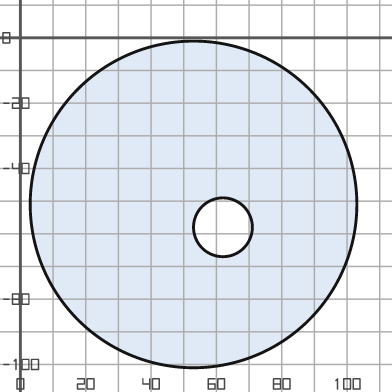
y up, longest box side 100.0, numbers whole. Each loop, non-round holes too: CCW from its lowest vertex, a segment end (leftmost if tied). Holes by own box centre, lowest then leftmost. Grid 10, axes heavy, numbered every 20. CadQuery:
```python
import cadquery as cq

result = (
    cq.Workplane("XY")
    .moveTo(53.0, -51.0)
    .circle(50.0)
    .moveTo(62.0, -58.0)
    .circle(9.0)
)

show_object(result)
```